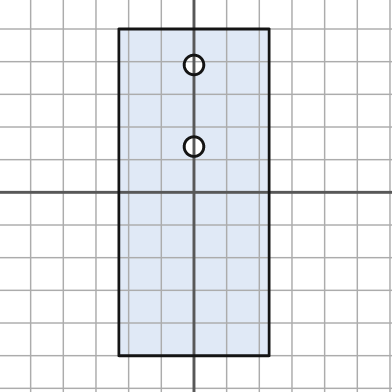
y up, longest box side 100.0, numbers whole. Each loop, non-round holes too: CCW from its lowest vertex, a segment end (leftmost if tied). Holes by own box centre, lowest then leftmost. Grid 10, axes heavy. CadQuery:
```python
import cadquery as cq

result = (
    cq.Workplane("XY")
    .moveTo(-23.0, -50.0)
    .lineTo(23.0, -50.0)
    .lineTo(23.0, 50.0)
    .lineTo(-23.0, 50.0)
    .close()
    .moveTo(0.0, 14.0)
    .circle(3.0)
    .moveTo(0.0, 39.0)
    .circle(3.0)
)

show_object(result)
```